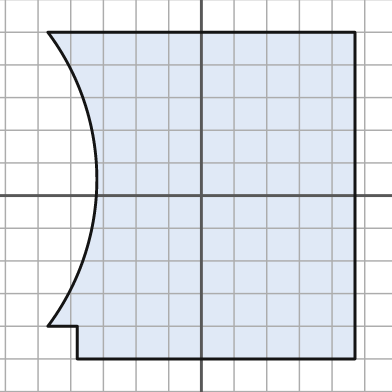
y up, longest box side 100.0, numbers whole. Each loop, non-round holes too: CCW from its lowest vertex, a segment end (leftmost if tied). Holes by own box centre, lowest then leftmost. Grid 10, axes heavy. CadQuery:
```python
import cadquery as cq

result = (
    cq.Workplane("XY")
    .moveTo(-38.0, -50.0)
    .lineTo(47.0, -50.0)
    .lineTo(47.0, 50.0)
    .lineTo(-47.0, 50.0)
    .threePointArc((-32.0, 5.0), (-47.0, -40.0))
    .lineTo(-38.0, -40.0)
    .close()
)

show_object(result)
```